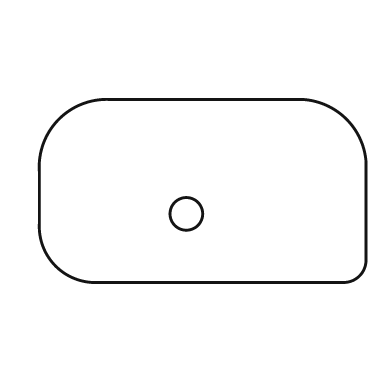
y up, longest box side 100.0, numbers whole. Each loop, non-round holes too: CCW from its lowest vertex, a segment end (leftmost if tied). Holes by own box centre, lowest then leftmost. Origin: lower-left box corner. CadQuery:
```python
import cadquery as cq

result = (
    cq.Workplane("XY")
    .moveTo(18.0, 0.0)
    .lineTo(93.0, 0.0)
    .threePointArc((98.0, 2.0), (100.0, 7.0))
    .lineTo(100.0, 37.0)
    .threePointArc((94.0, 50.0), (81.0, 56.0))
    .lineTo(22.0, 56.0)
    .threePointArc((6.0, 50.0), (0.0, 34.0))
    .lineTo(0.0, 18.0)
    .threePointArc((5.0, 5.0), (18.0, 0.0))
    .close()
    .moveTo(45.0, 21.0)
    .circle(5.0)
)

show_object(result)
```